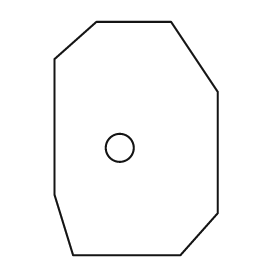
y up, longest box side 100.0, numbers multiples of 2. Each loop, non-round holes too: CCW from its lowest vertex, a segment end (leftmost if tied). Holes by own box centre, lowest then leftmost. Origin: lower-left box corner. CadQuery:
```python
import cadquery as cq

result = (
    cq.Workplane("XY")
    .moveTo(8.0, 0.0)
    .lineTo(54.0, 0.0)
    .lineTo(70.0, 18.0)
    .lineTo(70.0, 70.0)
    .lineTo(50.0, 100.0)
    .lineTo(18.0, 100.0)
    .lineTo(0.0, 84.0)
    .lineTo(0.0, 26.0)
    .close()
    .moveTo(28.0, 46.0)
    .circle(6.0)
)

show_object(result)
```